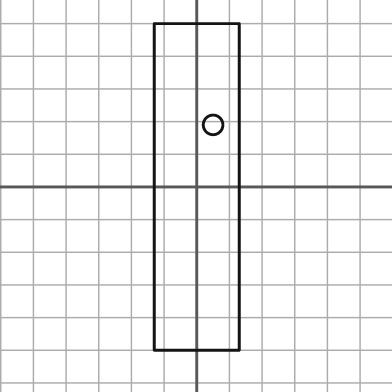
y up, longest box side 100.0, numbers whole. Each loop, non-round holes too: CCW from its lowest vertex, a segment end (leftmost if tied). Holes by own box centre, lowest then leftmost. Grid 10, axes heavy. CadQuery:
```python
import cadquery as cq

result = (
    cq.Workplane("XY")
    .moveTo(-13.0, -50.0)
    .lineTo(13.0, -50.0)
    .lineTo(13.0, 50.0)
    .lineTo(-13.0, 50.0)
    .close()
    .moveTo(5.0, 19.0)
    .circle(3.0)
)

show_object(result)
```